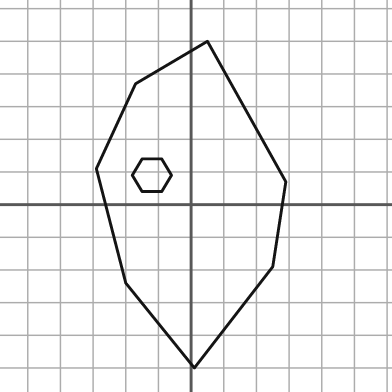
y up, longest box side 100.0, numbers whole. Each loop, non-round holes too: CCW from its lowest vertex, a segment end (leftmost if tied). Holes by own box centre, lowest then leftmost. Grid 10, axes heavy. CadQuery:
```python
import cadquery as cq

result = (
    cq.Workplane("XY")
    .moveTo(1.0, -50.0)
    .lineTo(25.0, -19.0)
    .lineTo(29.0, 7.0)
    .lineTo(5.0, 50.0)
    .lineTo(-17.0, 37.0)
    .lineTo(-29.0, 11.0)
    .lineTo(-20.0, -24.0)
    .close()
    .moveTo(-15.0, 4.0)
    .lineTo(-9.0, 4.0)
    .lineTo(-6.0, 9.0)
    .lineTo(-9.0, 14.0)
    .lineTo(-15.0, 14.0)
    .lineTo(-18.0, 9.0)
    .close()
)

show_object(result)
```